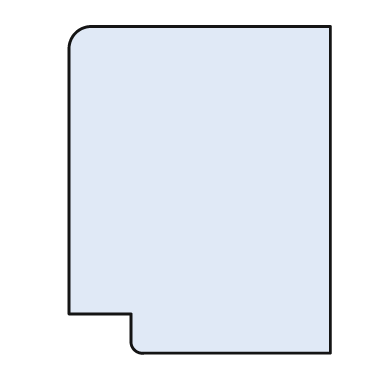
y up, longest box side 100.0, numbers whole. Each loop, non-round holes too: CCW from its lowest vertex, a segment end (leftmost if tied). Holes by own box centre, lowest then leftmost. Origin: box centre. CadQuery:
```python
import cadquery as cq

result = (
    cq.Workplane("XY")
    .moveTo(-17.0, -50.0)
    .lineTo(40.0, -50.0)
    .lineTo(40.0, 50.0)
    .lineTo(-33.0, 50.0)
    .threePointArc((-38.0, 48.0), (-40.0, 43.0))
    .lineTo(-40.0, -38.0)
    .lineTo(-21.0, -38.0)
    .lineTo(-21.0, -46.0)
    .threePointArc((-20.0, -49.0), (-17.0, -50.0))
    .close()
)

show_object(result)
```